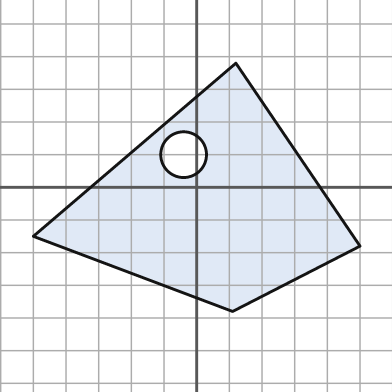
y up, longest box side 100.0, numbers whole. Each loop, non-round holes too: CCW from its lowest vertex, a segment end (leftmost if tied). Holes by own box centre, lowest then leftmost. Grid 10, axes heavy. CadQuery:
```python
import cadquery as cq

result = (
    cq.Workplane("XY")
    .moveTo(11.0, -38.0)
    .lineTo(50.0, -18.0)
    .lineTo(12.0, 38.0)
    .lineTo(-50.0, -15.0)
    .close()
    .moveTo(-4.0, 10.0)
    .circle(7.0)
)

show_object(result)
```